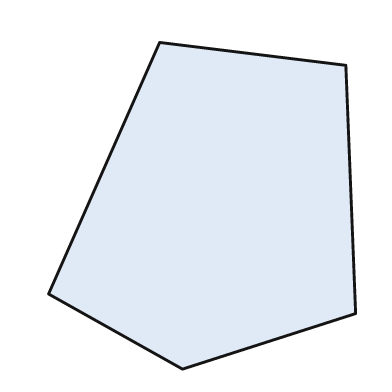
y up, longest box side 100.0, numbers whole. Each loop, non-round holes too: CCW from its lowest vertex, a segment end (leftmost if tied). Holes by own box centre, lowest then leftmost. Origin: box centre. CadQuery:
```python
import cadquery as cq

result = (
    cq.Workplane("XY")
    .moveTo(-6.0, -50.0)
    .lineTo(47.0, -33.0)
    .lineTo(44.0, 43.0)
    .lineTo(-13.0, 50.0)
    .lineTo(-47.0, -27.0)
    .close()
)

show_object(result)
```